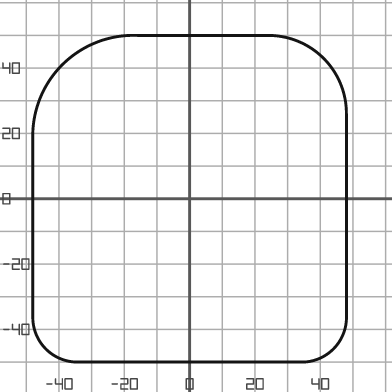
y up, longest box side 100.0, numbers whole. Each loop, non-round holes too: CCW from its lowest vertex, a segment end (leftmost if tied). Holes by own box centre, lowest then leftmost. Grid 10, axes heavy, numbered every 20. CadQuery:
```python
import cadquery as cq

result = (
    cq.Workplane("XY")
    .moveTo(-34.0, -50.0)
    .lineTo(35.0, -50.0)
    .threePointArc((44.0, -46.0), (48.0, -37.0))
    .lineTo(48.0, 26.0)
    .threePointArc((41.0, 43.0), (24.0, 50.0))
    .lineTo(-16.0, 50.0)
    .threePointArc((-39.0, 41.0), (-48.0, 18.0))
    .lineTo(-48.0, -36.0)
    .threePointArc((-44.0, -46.0), (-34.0, -50.0))
    .close()
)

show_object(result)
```